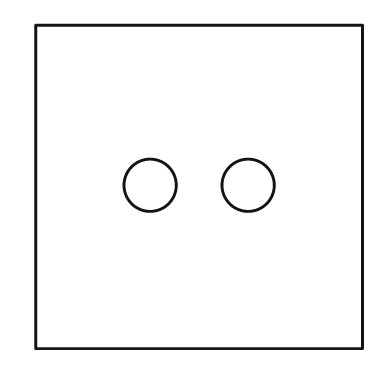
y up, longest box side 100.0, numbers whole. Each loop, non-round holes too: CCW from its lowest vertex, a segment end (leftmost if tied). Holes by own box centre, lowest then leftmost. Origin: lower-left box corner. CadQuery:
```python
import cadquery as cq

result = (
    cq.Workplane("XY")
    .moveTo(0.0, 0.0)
    .lineTo(100.0, 0.0)
    .lineTo(100.0, 99.0)
    .lineTo(0.0, 99.0)
    .close()
    .moveTo(35.0, 50.0)
    .circle(8.0)
    .moveTo(65.0, 50.0)
    .circle(8.0)
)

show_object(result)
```